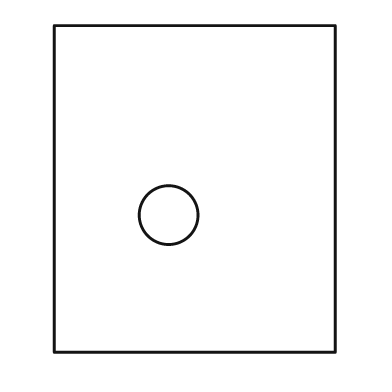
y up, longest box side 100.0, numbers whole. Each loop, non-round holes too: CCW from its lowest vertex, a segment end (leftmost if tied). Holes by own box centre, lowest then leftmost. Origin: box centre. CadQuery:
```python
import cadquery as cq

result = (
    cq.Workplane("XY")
    .moveTo(-43.0, -50.0)
    .lineTo(43.0, -50.0)
    .lineTo(43.0, 50.0)
    .lineTo(-43.0, 50.0)
    .close()
    .moveTo(-8.0, -8.0)
    .circle(9.0)
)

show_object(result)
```